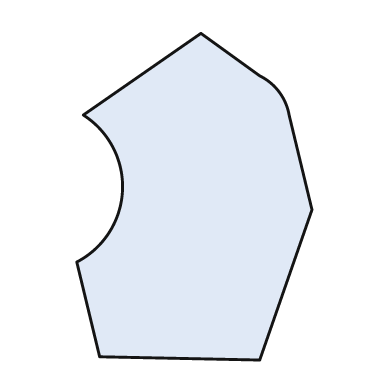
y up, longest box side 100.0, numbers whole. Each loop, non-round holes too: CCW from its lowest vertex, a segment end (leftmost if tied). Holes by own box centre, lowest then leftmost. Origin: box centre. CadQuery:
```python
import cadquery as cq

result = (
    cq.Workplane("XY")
    .moveTo(20.0, -50.0)
    .lineTo(36.0, -4.0)
    .lineTo(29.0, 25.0)
    .threePointArc((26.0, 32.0), (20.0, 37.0))
    .lineTo(2.0, 50.0)
    .lineTo(-34.0, 25.0)
    .threePointArc((-22.0, 2.0), (-36.0, -20.0))
    .lineTo(-29.0, -49.0)
    .close()
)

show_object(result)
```